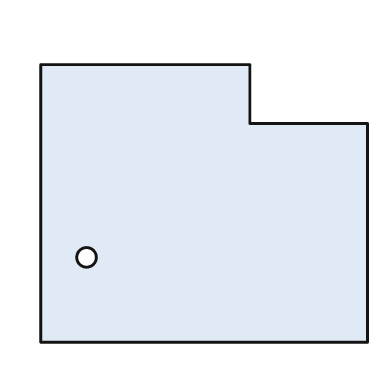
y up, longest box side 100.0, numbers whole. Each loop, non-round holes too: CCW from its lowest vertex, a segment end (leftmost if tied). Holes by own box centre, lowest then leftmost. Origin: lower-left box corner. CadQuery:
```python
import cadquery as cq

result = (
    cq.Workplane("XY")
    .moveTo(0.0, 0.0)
    .lineTo(100.0, 0.0)
    .lineTo(100.0, 67.0)
    .lineTo(64.0, 67.0)
    .lineTo(64.0, 85.0)
    .lineTo(0.0, 85.0)
    .close()
    .moveTo(14.0, 26.0)
    .circle(3.0)
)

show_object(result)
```